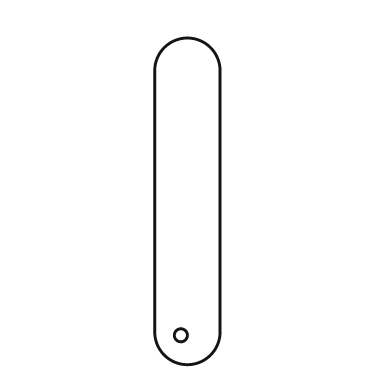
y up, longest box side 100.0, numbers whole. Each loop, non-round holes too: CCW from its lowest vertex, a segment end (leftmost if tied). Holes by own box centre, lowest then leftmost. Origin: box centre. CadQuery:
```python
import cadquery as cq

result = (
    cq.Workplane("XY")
    .moveTo(-10.0, -40.0)
    .threePointArc((0.0, -50.0), (10.0, -40.0))
    .lineTo(10.0, 40.0)
    .threePointArc((0.0, 50.0), (-10.0, 40.0))
    .close()
    .moveTo(-2.0, -41.0)
    .circle(2.0)
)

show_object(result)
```